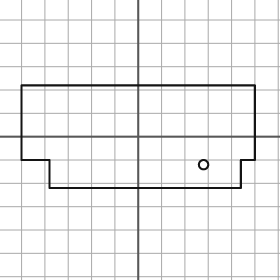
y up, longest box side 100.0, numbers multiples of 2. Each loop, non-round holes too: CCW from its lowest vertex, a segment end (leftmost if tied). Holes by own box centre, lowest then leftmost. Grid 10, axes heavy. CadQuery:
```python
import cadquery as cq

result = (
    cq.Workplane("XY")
    .moveTo(-38.0, -22.0)
    .lineTo(44.0, -22.0)
    .lineTo(44.0, -10.0)
    .lineTo(50.0, -10.0)
    .lineTo(50.0, 22.0)
    .lineTo(-50.0, 22.0)
    .lineTo(-50.0, -10.0)
    .lineTo(-38.0, -10.0)
    .close()
    .moveTo(28.0, -12.0)
    .circle(2.0)
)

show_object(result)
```